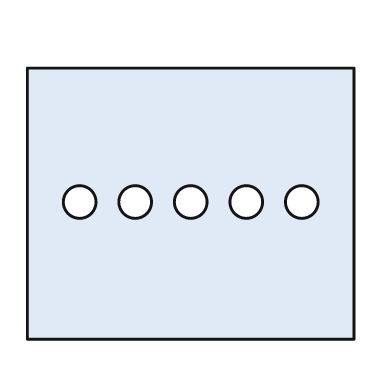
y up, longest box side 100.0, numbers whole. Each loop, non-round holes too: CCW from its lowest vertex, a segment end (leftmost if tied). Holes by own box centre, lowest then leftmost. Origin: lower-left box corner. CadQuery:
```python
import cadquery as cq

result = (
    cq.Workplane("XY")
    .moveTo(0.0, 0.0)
    .lineTo(100.0, 0.0)
    .lineTo(100.0, 83.0)
    .lineTo(0.0, 83.0)
    .close()
    .moveTo(16.0, 42.0)
    .circle(5.0)
    .moveTo(33.0, 42.0)
    .circle(5.0)
    .moveTo(50.0, 42.0)
    .circle(5.0)
    .moveTo(67.0, 42.0)
    .circle(5.0)
    .moveTo(84.0, 42.0)
    .circle(5.0)
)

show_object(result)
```